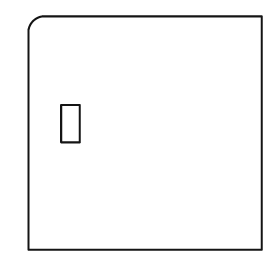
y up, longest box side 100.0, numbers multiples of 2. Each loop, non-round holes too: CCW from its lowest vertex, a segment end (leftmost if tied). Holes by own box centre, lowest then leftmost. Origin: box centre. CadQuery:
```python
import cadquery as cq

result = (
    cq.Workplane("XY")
    .moveTo(-50.0, -50.0)
    .lineTo(50.0, -50.0)
    .lineTo(50.0, 50.0)
    .lineTo(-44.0, 50.0)
    .threePointArc((-48.0, 48.0), (-50.0, 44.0))
    .close()
    .moveTo(-36.0, -4.0)
    .lineTo(-28.0, -4.0)
    .lineTo(-28.0, 12.0)
    .lineTo(-36.0, 12.0)
    .close()
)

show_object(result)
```